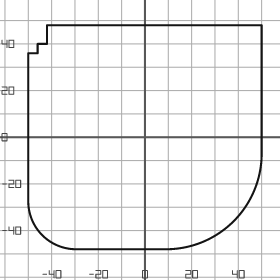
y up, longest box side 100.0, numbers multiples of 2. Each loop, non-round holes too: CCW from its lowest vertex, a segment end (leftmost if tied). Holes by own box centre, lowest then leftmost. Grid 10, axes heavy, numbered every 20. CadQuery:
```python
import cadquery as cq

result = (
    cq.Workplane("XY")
    .moveTo(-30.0, -48.0)
    .lineTo(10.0, -48.0)
    .threePointArc((38.0, -36.0), (50.0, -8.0))
    .lineTo(50.0, 48.0)
    .lineTo(-42.0, 48.0)
    .lineTo(-42.0, 40.0)
    .lineTo(-46.0, 40.0)
    .lineTo(-46.0, 36.0)
    .lineTo(-50.0, 36.0)
    .lineTo(-50.0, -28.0)
    .threePointArc((-44.0, -42.0), (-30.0, -48.0))
    .close()
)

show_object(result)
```